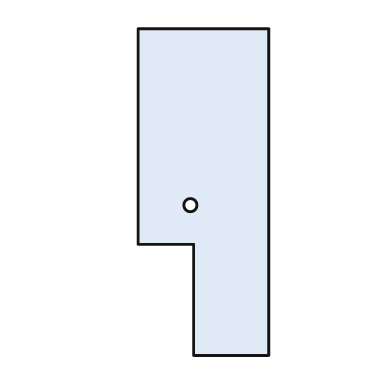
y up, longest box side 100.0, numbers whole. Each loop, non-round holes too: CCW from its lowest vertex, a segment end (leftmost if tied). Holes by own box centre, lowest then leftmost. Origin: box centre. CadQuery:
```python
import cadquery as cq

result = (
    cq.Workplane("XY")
    .moveTo(-3.0, -50.0)
    .lineTo(20.0, -50.0)
    .lineTo(20.0, 50.0)
    .lineTo(-20.0, 50.0)
    .lineTo(-20.0, -16.0)
    .lineTo(-3.0, -16.0)
    .close()
    .moveTo(-4.0, -4.0)
    .circle(2.0)
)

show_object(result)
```